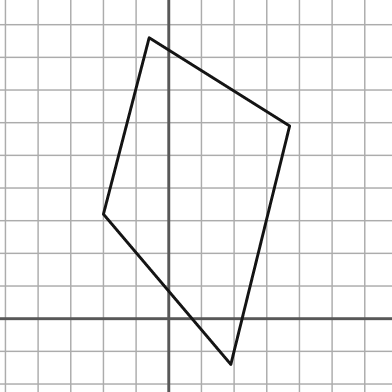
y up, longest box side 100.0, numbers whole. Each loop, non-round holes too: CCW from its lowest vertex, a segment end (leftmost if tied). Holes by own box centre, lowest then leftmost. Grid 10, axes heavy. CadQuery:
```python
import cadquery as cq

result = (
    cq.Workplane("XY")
    .moveTo(19.0, -14.0)
    .lineTo(37.0, 59.0)
    .lineTo(-6.0, 86.0)
    .lineTo(-20.0, 32.0)
    .close()
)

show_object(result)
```